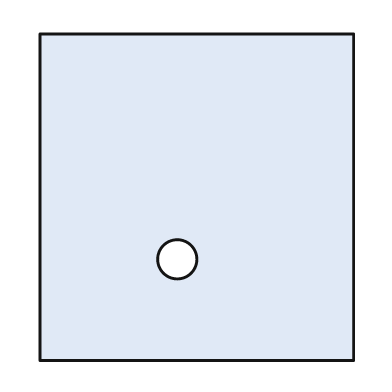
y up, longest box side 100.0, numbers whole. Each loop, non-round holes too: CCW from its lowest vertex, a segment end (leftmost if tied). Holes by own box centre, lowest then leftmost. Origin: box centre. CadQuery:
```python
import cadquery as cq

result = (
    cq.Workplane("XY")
    .moveTo(-48.0, -50.0)
    .lineTo(48.0, -50.0)
    .lineTo(48.0, 50.0)
    .lineTo(-48.0, 50.0)
    .close()
    .moveTo(-6.0, -19.0)
    .circle(6.0)
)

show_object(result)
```